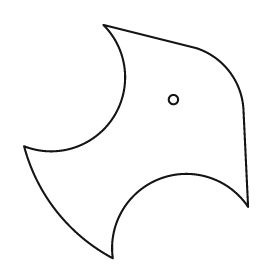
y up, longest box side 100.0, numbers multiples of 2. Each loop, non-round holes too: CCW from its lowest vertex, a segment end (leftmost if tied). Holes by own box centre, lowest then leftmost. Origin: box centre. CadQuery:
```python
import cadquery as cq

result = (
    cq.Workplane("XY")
    .moveTo(-10.0, -50.0)
    .threePointArc((10.0, -16.0), (48.0, -28.0))
    .lineTo(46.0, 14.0)
    .threePointArc((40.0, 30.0), (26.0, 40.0))
    .lineTo(-14.0, 50.0)
    .threePointArc((-10.0, 10.0), (-48.0, -2.0))
    .threePointArc((-34.0, -30.0), (-10.0, -50.0))
    .close()
    .moveTo(16.0, 18.0)
    .circle(2.0)
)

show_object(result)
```